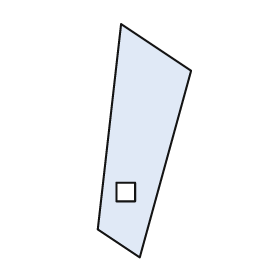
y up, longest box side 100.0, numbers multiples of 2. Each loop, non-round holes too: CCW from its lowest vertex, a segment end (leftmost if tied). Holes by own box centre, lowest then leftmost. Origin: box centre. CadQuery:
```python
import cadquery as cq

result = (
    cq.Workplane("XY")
    .moveTo(-2.0, -50.0)
    .lineTo(20.0, 30.0)
    .lineTo(-10.0, 50.0)
    .lineTo(-20.0, -38.0)
    .close()
    .moveTo(-12.0, -26.0)
    .lineTo(-4.0, -26.0)
    .lineTo(-4.0, -18.0)
    .lineTo(-12.0, -18.0)
    .close()
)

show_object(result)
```